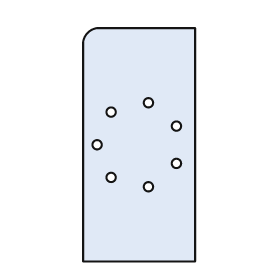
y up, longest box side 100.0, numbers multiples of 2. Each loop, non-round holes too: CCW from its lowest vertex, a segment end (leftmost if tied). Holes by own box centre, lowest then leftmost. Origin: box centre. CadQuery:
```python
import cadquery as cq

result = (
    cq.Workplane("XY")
    .moveTo(-24.0, -50.0)
    .lineTo(24.0, -50.0)
    .lineTo(24.0, 50.0)
    .lineTo(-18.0, 50.0)
    .threePointArc((-22.0, 48.0), (-24.0, 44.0))
    .close()
    .moveTo(4.0, -18.0)
    .circle(2.0)
    .moveTo(-12.0, -14.0)
    .circle(2.0)
    .moveTo(16.0, -8.0)
    .circle(2.0)
    .moveTo(-18.0, 0.0)
    .circle(2.0)
    .moveTo(16.0, 8.0)
    .circle(2.0)
    .moveTo(-12.0, 14.0)
    .circle(2.0)
    .moveTo(4.0, 18.0)
    .circle(2.0)
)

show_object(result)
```